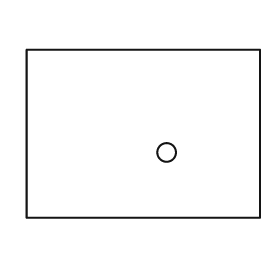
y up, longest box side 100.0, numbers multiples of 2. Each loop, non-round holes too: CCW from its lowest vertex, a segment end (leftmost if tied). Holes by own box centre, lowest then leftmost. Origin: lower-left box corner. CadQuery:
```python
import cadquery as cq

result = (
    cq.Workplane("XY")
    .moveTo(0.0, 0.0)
    .lineTo(100.0, 0.0)
    .lineTo(100.0, 72.0)
    .lineTo(0.0, 72.0)
    .close()
    .moveTo(60.0, 28.0)
    .circle(4.0)
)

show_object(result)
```